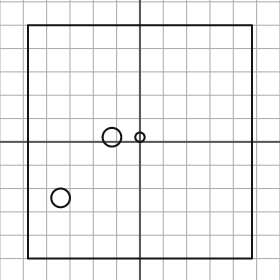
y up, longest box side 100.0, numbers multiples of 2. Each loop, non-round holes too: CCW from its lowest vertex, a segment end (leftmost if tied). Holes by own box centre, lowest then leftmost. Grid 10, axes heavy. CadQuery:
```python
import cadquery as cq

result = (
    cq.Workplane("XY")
    .moveTo(-48.0, -50.0)
    .lineTo(48.0, -50.0)
    .lineTo(48.0, 50.0)
    .lineTo(-48.0, 50.0)
    .close()
    .moveTo(-34.0, -24.0)
    .circle(4.0)
    .moveTo(-12.0, 2.0)
    .circle(4.0)
    .moveTo(0.0, 2.0)
    .circle(2.0)
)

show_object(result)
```